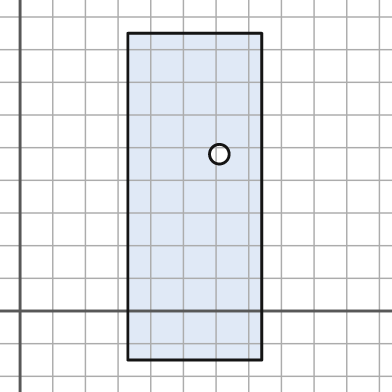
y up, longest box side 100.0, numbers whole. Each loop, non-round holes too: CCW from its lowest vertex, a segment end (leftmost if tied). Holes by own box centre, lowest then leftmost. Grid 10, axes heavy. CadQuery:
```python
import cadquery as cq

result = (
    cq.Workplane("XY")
    .moveTo(33.0, -15.0)
    .lineTo(74.0, -15.0)
    .lineTo(74.0, 85.0)
    .lineTo(33.0, 85.0)
    .close()
    .moveTo(61.0, 48.0)
    .circle(3.0)
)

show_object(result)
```